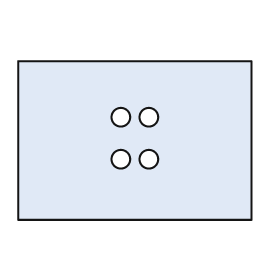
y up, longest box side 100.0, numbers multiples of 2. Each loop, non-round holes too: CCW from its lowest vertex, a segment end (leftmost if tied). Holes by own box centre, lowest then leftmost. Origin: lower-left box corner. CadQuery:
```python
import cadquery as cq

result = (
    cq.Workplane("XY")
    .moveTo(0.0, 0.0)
    .lineTo(100.0, 0.0)
    .lineTo(100.0, 68.0)
    .lineTo(0.0, 68.0)
    .close()
    .moveTo(44.0, 26.0)
    .circle(4.0)
    .moveTo(56.0, 26.0)
    .circle(4.0)
    .moveTo(44.0, 44.0)
    .circle(4.0)
    .moveTo(56.0, 44.0)
    .circle(4.0)
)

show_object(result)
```